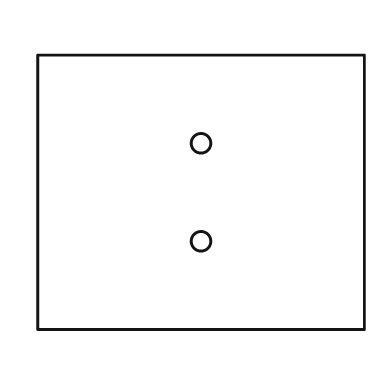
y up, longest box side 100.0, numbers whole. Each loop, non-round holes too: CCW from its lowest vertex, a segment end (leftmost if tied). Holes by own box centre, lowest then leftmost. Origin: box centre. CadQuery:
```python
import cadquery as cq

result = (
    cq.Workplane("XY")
    .moveTo(-50.0, -42.0)
    .lineTo(50.0, -42.0)
    .lineTo(50.0, 42.0)
    .lineTo(-50.0, 42.0)
    .close()
    .moveTo(0.0, -15.0)
    .circle(3.0)
    .moveTo(0.0, 15.0)
    .circle(3.0)
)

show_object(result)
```